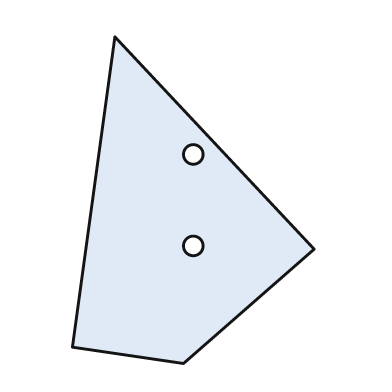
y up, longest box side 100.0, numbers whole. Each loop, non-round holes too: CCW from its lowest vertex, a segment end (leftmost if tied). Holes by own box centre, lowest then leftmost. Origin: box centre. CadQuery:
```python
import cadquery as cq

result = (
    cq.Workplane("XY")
    .moveTo(-3.0, -50.0)
    .lineTo(37.0, -15.0)
    .lineTo(-24.0, 50.0)
    .lineTo(-37.0, -45.0)
    .close()
    .moveTo(0.0, -14.0)
    .circle(3.0)
    .moveTo(0.0, 14.0)
    .circle(3.0)
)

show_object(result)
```